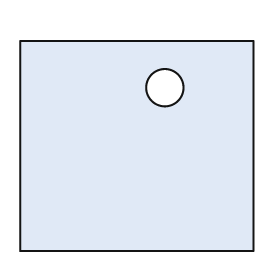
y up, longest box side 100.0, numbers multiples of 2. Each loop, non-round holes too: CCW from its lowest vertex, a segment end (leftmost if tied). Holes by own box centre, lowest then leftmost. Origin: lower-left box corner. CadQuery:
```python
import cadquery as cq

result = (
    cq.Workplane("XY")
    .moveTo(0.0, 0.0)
    .lineTo(100.0, 0.0)
    .lineTo(100.0, 90.0)
    .lineTo(0.0, 90.0)
    .close()
    .moveTo(62.0, 70.0)
    .circle(8.0)
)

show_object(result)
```